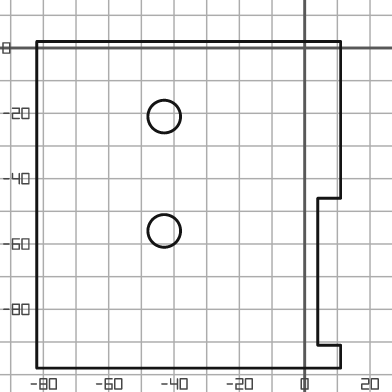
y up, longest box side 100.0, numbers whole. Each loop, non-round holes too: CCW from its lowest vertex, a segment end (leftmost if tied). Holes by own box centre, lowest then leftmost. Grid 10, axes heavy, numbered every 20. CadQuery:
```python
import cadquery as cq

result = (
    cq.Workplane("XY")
    .moveTo(-82.0, -98.0)
    .lineTo(11.0, -98.0)
    .lineTo(11.0, -91.0)
    .lineTo(4.0, -91.0)
    .lineTo(4.0, -46.0)
    .lineTo(11.0, -46.0)
    .lineTo(11.0, 2.0)
    .lineTo(-82.0, 2.0)
    .close()
    .moveTo(-43.0, -56.0)
    .circle(5.0)
    .moveTo(-43.0, -21.0)
    .circle(5.0)
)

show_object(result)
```